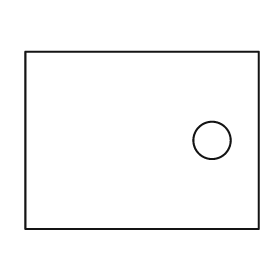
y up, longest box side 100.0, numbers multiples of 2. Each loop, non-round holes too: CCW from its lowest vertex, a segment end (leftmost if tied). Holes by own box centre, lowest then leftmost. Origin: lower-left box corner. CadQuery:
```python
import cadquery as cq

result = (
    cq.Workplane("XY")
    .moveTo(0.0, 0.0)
    .lineTo(100.0, 0.0)
    .lineTo(100.0, 76.0)
    .lineTo(0.0, 76.0)
    .close()
    .moveTo(80.0, 38.0)
    .circle(8.0)
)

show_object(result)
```